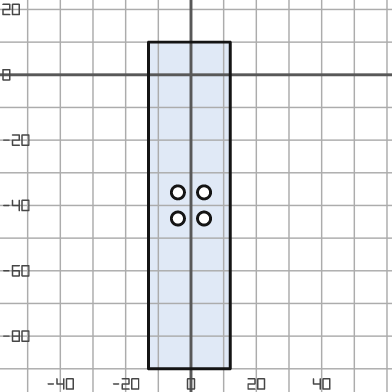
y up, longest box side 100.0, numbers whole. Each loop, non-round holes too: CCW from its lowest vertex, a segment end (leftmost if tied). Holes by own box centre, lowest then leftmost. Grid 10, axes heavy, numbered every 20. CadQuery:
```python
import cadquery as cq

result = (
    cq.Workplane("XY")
    .moveTo(-13.0, -90.0)
    .lineTo(12.0, -90.0)
    .lineTo(12.0, 10.0)
    .lineTo(-13.0, 10.0)
    .close()
    .moveTo(-4.0, -44.0)
    .circle(2.0)
    .moveTo(4.0, -44.0)
    .circle(2.0)
    .moveTo(-4.0, -36.0)
    .circle(2.0)
    .moveTo(4.0, -36.0)
    .circle(2.0)
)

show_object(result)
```